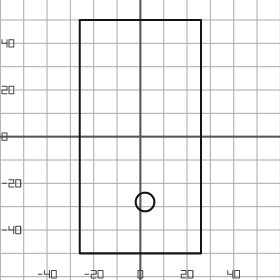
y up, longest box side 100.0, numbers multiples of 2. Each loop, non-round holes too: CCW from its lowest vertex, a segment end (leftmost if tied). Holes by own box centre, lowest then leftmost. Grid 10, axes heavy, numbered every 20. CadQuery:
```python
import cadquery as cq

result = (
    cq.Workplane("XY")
    .moveTo(-26.0, -50.0)
    .lineTo(26.0, -50.0)
    .lineTo(26.0, 50.0)
    .lineTo(-26.0, 50.0)
    .close()
    .moveTo(2.0, -28.0)
    .circle(4.0)
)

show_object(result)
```